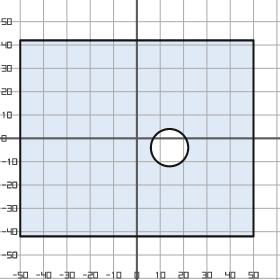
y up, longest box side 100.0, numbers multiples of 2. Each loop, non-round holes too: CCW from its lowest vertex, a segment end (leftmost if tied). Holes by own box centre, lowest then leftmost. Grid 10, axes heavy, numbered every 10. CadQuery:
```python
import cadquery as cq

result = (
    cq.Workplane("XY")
    .moveTo(-50.0, -42.0)
    .lineTo(50.0, -42.0)
    .lineTo(50.0, 42.0)
    .lineTo(-50.0, 42.0)
    .close()
    .moveTo(14.0, -4.0)
    .circle(8.0)
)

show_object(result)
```